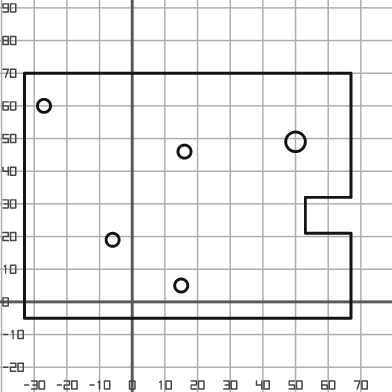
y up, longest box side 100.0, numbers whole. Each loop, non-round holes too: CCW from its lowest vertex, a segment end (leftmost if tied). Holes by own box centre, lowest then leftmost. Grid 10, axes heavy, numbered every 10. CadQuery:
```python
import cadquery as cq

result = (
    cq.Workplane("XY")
    .moveTo(-33.0, -5.0)
    .lineTo(67.0, -5.0)
    .lineTo(67.0, 21.0)
    .lineTo(53.0, 21.0)
    .lineTo(53.0, 32.0)
    .lineTo(67.0, 32.0)
    .lineTo(67.0, 70.0)
    .lineTo(-33.0, 70.0)
    .close()
    .moveTo(15.0, 5.0)
    .circle(2.0)
    .moveTo(-6.0, 19.0)
    .circle(2.0)
    .moveTo(16.0, 46.0)
    .circle(2.0)
    .moveTo(50.0, 49.0)
    .circle(3.0)
    .moveTo(-27.0, 60.0)
    .circle(2.0)
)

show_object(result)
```